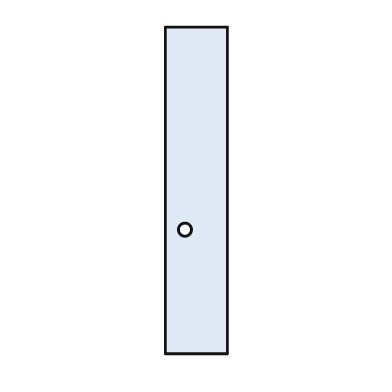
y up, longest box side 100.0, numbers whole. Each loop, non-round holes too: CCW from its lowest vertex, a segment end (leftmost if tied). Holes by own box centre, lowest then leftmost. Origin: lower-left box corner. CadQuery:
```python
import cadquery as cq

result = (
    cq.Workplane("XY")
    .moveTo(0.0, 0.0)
    .lineTo(19.0, 0.0)
    .lineTo(19.0, 100.0)
    .lineTo(0.0, 100.0)
    .close()
    .moveTo(6.0, 38.0)
    .circle(2.0)
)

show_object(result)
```